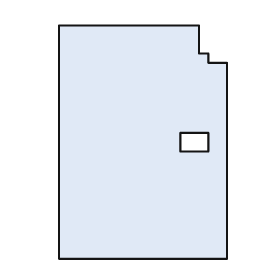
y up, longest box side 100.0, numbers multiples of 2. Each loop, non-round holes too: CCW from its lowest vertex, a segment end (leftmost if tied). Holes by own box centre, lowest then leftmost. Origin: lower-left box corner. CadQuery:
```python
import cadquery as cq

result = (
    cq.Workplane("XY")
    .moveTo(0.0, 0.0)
    .lineTo(72.0, 0.0)
    .lineTo(72.0, 84.0)
    .lineTo(64.0, 84.0)
    .lineTo(64.0, 88.0)
    .lineTo(60.0, 88.0)
    .lineTo(60.0, 100.0)
    .lineTo(0.0, 100.0)
    .close()
    .moveTo(52.0, 46.0)
    .lineTo(64.0, 46.0)
    .lineTo(64.0, 54.0)
    .lineTo(52.0, 54.0)
    .close()
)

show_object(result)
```